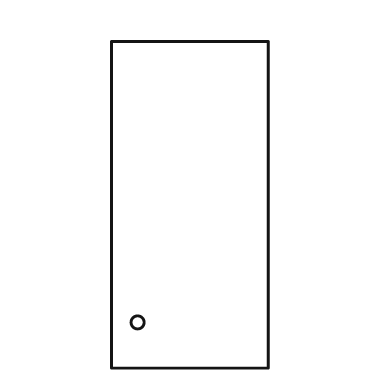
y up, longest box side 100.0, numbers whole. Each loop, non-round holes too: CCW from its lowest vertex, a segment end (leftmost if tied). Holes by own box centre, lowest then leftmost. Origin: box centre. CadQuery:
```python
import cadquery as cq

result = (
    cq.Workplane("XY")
    .moveTo(-24.0, -50.0)
    .lineTo(24.0, -50.0)
    .lineTo(24.0, 50.0)
    .lineTo(-24.0, 50.0)
    .close()
    .moveTo(-16.0, -36.0)
    .circle(2.0)
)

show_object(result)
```